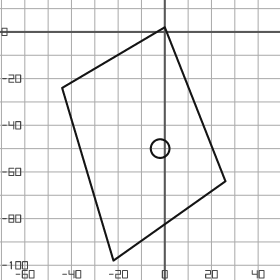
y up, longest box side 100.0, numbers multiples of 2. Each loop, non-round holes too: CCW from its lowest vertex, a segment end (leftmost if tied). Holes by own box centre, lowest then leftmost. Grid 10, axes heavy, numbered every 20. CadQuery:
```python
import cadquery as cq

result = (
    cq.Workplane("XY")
    .moveTo(-22.0, -98.0)
    .lineTo(26.0, -64.0)
    .lineTo(0.0, 2.0)
    .lineTo(-44.0, -24.0)
    .close()
    .moveTo(-2.0, -50.0)
    .circle(4.0)
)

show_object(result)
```